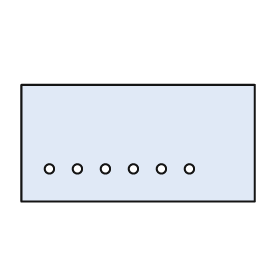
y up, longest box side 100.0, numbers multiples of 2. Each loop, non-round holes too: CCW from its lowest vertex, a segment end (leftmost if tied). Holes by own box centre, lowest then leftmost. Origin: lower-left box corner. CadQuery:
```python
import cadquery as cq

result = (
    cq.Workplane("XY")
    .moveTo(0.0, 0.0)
    .lineTo(100.0, 0.0)
    .lineTo(100.0, 50.0)
    .lineTo(0.0, 50.0)
    .close()
    .moveTo(12.0, 14.0)
    .circle(2.0)
    .moveTo(24.0, 14.0)
    .circle(2.0)
    .moveTo(36.0, 14.0)
    .circle(2.0)
    .moveTo(48.0, 14.0)
    .circle(2.0)
    .moveTo(60.0, 14.0)
    .circle(2.0)
    .moveTo(72.0, 14.0)
    .circle(2.0)
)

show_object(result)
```